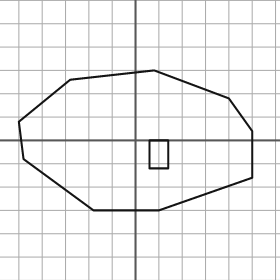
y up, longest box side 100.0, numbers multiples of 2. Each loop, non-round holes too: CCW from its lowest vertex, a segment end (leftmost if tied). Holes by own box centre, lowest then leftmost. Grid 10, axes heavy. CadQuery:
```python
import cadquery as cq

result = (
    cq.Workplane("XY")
    .moveTo(-18.0, -30.0)
    .lineTo(10.0, -30.0)
    .lineTo(50.0, -16.0)
    .lineTo(50.0, 4.0)
    .lineTo(40.0, 18.0)
    .lineTo(8.0, 30.0)
    .lineTo(-28.0, 26.0)
    .lineTo(-50.0, 8.0)
    .lineTo(-48.0, -8.0)
    .close()
    .moveTo(6.0, -12.0)
    .lineTo(14.0, -12.0)
    .lineTo(14.0, 0.0)
    .lineTo(6.0, 0.0)
    .close()
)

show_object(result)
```